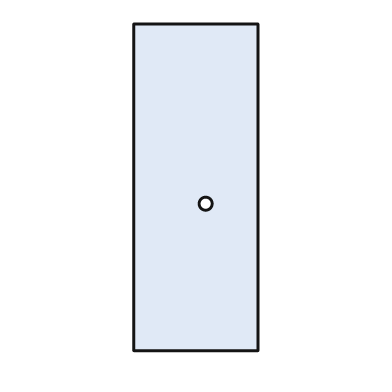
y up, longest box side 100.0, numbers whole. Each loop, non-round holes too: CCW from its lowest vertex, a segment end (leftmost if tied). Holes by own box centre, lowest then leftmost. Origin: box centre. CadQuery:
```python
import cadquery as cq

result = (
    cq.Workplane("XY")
    .moveTo(-19.0, -50.0)
    .lineTo(19.0, -50.0)
    .lineTo(19.0, 50.0)
    .lineTo(-19.0, 50.0)
    .close()
    .moveTo(3.0, -5.0)
    .circle(2.0)
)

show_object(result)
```